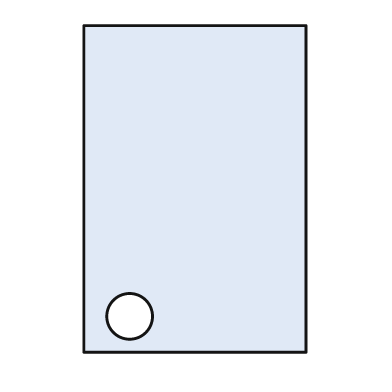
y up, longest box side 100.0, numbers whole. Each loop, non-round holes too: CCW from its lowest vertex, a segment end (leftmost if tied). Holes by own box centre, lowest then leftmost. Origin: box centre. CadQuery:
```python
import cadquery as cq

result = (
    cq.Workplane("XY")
    .moveTo(-34.0, -50.0)
    .lineTo(34.0, -50.0)
    .lineTo(34.0, 50.0)
    .lineTo(-34.0, 50.0)
    .close()
    .moveTo(-20.0, -39.0)
    .circle(7.0)
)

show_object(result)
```